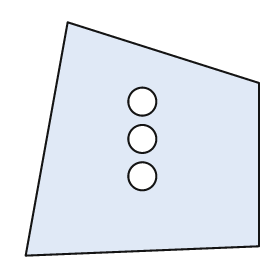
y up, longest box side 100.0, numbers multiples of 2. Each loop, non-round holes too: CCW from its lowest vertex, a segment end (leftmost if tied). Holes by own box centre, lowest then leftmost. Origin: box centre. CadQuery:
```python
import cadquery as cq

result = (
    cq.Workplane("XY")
    .moveTo(-50.0, -50.0)
    .lineTo(50.0, -46.0)
    .lineTo(50.0, 24.0)
    .lineTo(-32.0, 50.0)
    .close()
    .moveTo(0.0, -16.0)
    .circle(6.0)
    .moveTo(0.0, 0.0)
    .circle(6.0)
    .moveTo(0.0, 16.0)
    .circle(6.0)
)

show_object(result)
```